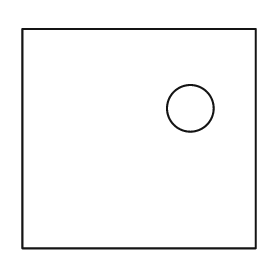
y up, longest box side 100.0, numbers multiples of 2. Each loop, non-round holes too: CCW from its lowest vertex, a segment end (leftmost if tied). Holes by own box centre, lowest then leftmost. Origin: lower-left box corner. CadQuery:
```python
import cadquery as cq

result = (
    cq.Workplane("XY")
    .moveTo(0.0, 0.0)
    .lineTo(100.0, 0.0)
    .lineTo(100.0, 94.0)
    .lineTo(0.0, 94.0)
    .close()
    .moveTo(72.0, 60.0)
    .circle(10.0)
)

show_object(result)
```